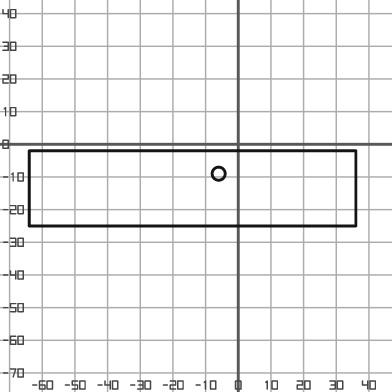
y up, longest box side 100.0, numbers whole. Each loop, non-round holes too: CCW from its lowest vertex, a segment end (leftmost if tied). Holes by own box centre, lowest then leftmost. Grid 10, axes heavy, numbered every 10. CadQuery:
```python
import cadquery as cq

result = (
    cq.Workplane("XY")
    .moveTo(-64.0, -25.0)
    .lineTo(36.0, -25.0)
    .lineTo(36.0, -2.0)
    .lineTo(-64.0, -2.0)
    .close()
    .moveTo(-6.0, -9.0)
    .circle(2.0)
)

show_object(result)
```